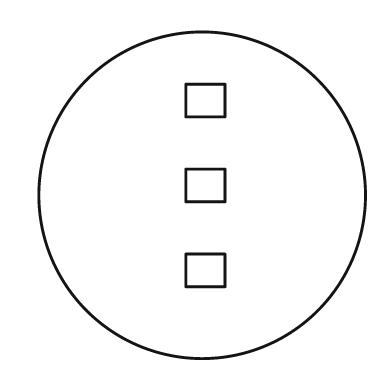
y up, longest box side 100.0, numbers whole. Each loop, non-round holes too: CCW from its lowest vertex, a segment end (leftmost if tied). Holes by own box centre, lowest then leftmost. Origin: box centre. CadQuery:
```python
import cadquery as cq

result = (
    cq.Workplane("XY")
    .moveTo(0.0, 0.0)
    .circle(50.0)
    .moveTo(-5.0, -28.0)
    .lineTo(7.0, -28.0)
    .lineTo(7.0, -18.0)
    .lineTo(-5.0, -18.0)
    .close()
    .moveTo(-5.0, -2.0)
    .lineTo(7.0, -2.0)
    .lineTo(7.0, 8.0)
    .lineTo(-5.0, 8.0)
    .close()
    .moveTo(-5.0, 24.0)
    .lineTo(7.0, 24.0)
    .lineTo(7.0, 34.0)
    .lineTo(-5.0, 34.0)
    .close()
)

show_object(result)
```